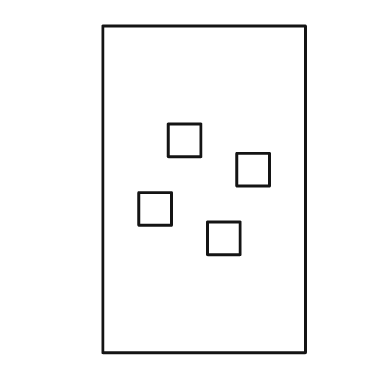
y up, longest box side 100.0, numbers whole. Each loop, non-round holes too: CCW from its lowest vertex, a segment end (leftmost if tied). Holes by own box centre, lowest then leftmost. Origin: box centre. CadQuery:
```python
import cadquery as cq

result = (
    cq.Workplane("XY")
    .moveTo(-31.0, -50.0)
    .lineTo(31.0, -50.0)
    .lineTo(31.0, 50.0)
    .lineTo(-31.0, 50.0)
    .close()
    .moveTo(1.0, -20.0)
    .lineTo(11.0, -20.0)
    .lineTo(11.0, -10.0)
    .lineTo(1.0, -10.0)
    .close()
    .moveTo(-20.0, -11.0)
    .lineTo(-10.0, -11.0)
    .lineTo(-10.0, -1.0)
    .lineTo(-20.0, -1.0)
    .close()
    .moveTo(10.0, 1.0)
    .lineTo(20.0, 1.0)
    .lineTo(20.0, 11.0)
    .lineTo(10.0, 11.0)
    .close()
    .moveTo(-11.0, 10.0)
    .lineTo(-1.0, 10.0)
    .lineTo(-1.0, 20.0)
    .lineTo(-11.0, 20.0)
    .close()
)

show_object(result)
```